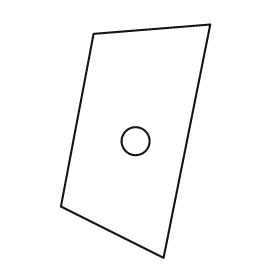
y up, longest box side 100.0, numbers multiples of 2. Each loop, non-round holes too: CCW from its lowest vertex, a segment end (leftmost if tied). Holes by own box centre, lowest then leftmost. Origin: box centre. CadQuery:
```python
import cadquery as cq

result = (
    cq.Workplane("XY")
    .moveTo(12.0, -50.0)
    .lineTo(32.0, 50.0)
    .lineTo(-18.0, 46.0)
    .lineTo(-32.0, -28.0)
    .close()
    .moveTo(0.0, 0.0)
    .circle(6.0)
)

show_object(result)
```